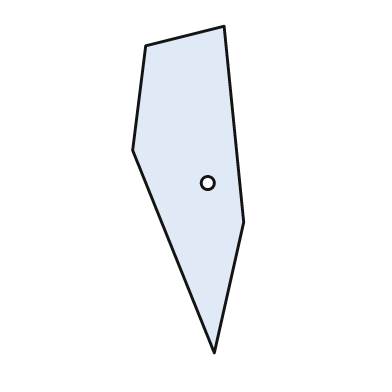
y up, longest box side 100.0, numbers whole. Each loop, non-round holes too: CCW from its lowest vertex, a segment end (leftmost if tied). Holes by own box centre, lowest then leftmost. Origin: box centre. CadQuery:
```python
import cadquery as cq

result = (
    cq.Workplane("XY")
    .moveTo(8.0, -50.0)
    .lineTo(17.0, -10.0)
    .lineTo(11.0, 50.0)
    .lineTo(-13.0, 44.0)
    .lineTo(-17.0, 12.0)
    .close()
    .moveTo(6.0, 2.0)
    .circle(2.0)
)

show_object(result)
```